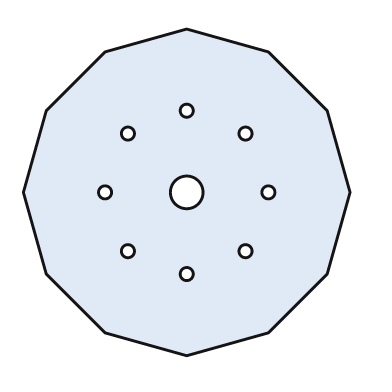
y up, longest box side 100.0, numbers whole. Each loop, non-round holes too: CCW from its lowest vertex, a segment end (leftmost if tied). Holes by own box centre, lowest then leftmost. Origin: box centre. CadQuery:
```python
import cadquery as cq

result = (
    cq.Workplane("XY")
    .moveTo(0.0, -50.0)
    .lineTo(25.0, -43.0)
    .lineTo(43.0, -25.0)
    .lineTo(50.0, 0.0)
    .lineTo(43.0, 25.0)
    .lineTo(25.0, 43.0)
    .lineTo(0.0, 50.0)
    .lineTo(-25.0, 43.0)
    .lineTo(-43.0, 25.0)
    .lineTo(-50.0, 0.0)
    .lineTo(-43.0, -25.0)
    .lineTo(-25.0, -43.0)
    .close()
    .moveTo(0.0, -25.0)
    .circle(2.0)
    .moveTo(-18.0, -18.0)
    .circle(2.0)
    .moveTo(18.0, -18.0)
    .circle(2.0)
    .moveTo(-25.0, 0.0)
    .circle(2.0)
    .moveTo(0.0, 0.0)
    .circle(5.0)
    .moveTo(25.0, 0.0)
    .circle(2.0)
    .moveTo(-18.0, 18.0)
    .circle(2.0)
    .moveTo(18.0, 18.0)
    .circle(2.0)
    .moveTo(0.0, 25.0)
    .circle(2.0)
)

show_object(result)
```